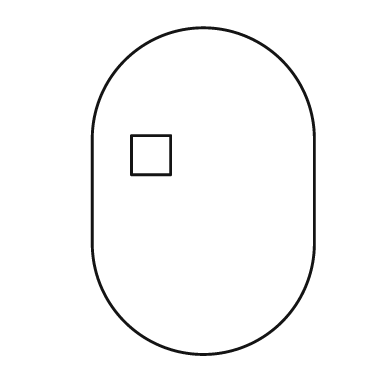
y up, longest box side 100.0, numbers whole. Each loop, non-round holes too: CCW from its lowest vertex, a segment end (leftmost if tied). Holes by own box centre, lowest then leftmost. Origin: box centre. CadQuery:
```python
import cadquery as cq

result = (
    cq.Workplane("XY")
    .moveTo(-34.0, -16.0)
    .threePointArc((0.0, -50.0), (34.0, -16.0))
    .lineTo(34.0, 16.0)
    .threePointArc((0.0, 50.0), (-34.0, 16.0))
    .close()
    .moveTo(-22.0, 5.0)
    .lineTo(-10.0, 5.0)
    .lineTo(-10.0, 17.0)
    .lineTo(-22.0, 17.0)
    .close()
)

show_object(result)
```